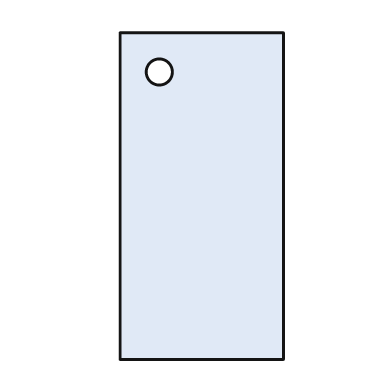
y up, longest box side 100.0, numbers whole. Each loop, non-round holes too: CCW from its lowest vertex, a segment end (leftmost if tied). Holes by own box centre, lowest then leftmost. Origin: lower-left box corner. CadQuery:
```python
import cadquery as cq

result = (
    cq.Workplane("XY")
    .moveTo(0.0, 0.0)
    .lineTo(50.0, 0.0)
    .lineTo(50.0, 100.0)
    .lineTo(0.0, 100.0)
    .close()
    .moveTo(12.0, 88.0)
    .circle(4.0)
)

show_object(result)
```